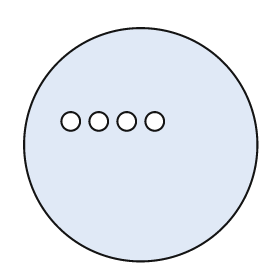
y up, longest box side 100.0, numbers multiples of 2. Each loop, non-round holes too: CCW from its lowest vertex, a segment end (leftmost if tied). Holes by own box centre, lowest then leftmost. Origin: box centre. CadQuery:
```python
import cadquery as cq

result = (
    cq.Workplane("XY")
    .moveTo(0.0, 0.0)
    .circle(50.0)
    .moveTo(-30.0, 10.0)
    .circle(4.0)
    .moveTo(-18.0, 10.0)
    .circle(4.0)
    .moveTo(-6.0, 10.0)
    .circle(4.0)
    .moveTo(6.0, 10.0)
    .circle(4.0)
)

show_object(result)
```